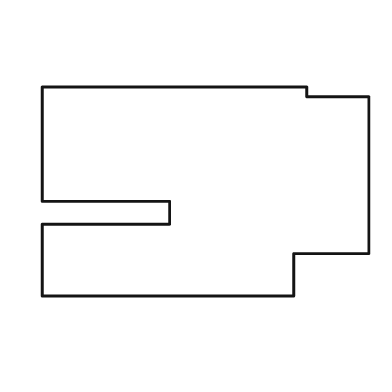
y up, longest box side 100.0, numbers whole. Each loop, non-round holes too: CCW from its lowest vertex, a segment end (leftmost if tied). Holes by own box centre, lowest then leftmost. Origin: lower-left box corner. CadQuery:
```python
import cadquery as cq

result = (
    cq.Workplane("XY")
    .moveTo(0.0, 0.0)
    .lineTo(77.0, 0.0)
    .lineTo(77.0, 13.0)
    .lineTo(100.0, 13.0)
    .lineTo(100.0, 61.0)
    .lineTo(81.0, 61.0)
    .lineTo(81.0, 64.0)
    .lineTo(0.0, 64.0)
    .lineTo(0.0, 29.0)
    .lineTo(39.0, 29.0)
    .lineTo(39.0, 22.0)
    .lineTo(0.0, 22.0)
    .close()
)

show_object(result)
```